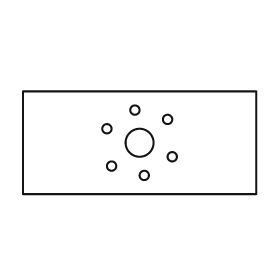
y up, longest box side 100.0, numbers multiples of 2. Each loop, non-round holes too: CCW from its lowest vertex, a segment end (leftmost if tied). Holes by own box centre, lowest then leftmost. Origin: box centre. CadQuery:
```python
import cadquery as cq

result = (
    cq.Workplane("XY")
    .moveTo(-50.0, -22.0)
    .lineTo(50.0, -22.0)
    .lineTo(50.0, 22.0)
    .lineTo(-50.0, 22.0)
    .close()
    .moveTo(2.0, -14.0)
    .circle(2.0)
    .moveTo(-12.0, -10.0)
    .circle(2.0)
    .moveTo(14.0, -6.0)
    .circle(2.0)
    .moveTo(0.0, 0.0)
    .circle(6.0)
    .moveTo(-14.0, 6.0)
    .circle(2.0)
    .moveTo(12.0, 10.0)
    .circle(2.0)
    .moveTo(-2.0, 14.0)
    .circle(2.0)
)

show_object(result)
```